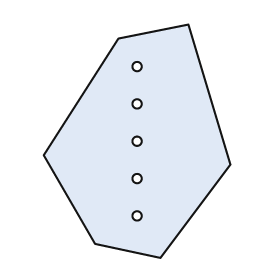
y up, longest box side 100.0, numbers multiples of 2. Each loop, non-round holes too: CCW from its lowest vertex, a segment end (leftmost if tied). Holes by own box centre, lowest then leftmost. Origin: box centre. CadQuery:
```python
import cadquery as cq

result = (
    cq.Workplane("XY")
    .moveTo(10.0, -50.0)
    .lineTo(40.0, -10.0)
    .lineTo(22.0, 50.0)
    .lineTo(-8.0, 44.0)
    .lineTo(-40.0, -6.0)
    .lineTo(-18.0, -44.0)
    .close()
    .moveTo(0.0, -32.0)
    .circle(2.0)
    .moveTo(0.0, -16.0)
    .circle(2.0)
    .moveTo(0.0, 0.0)
    .circle(2.0)
    .moveTo(0.0, 16.0)
    .circle(2.0)
    .moveTo(0.0, 32.0)
    .circle(2.0)
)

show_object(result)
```